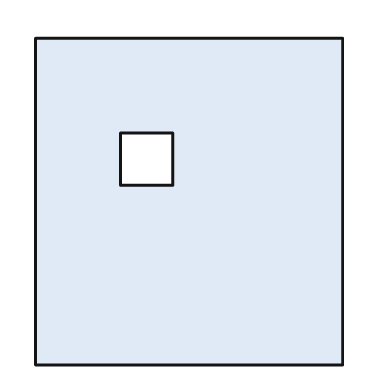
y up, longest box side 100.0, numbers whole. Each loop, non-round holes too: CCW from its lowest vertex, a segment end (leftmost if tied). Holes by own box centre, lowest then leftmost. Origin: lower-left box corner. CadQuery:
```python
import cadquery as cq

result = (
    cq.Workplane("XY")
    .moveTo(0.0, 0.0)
    .lineTo(94.0, 0.0)
    .lineTo(94.0, 100.0)
    .lineTo(0.0, 100.0)
    .close()
    .moveTo(26.0, 55.0)
    .lineTo(42.0, 55.0)
    .lineTo(42.0, 71.0)
    .lineTo(26.0, 71.0)
    .close()
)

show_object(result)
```